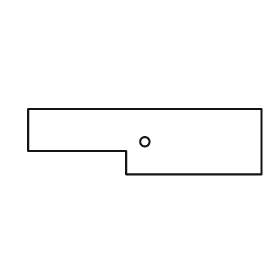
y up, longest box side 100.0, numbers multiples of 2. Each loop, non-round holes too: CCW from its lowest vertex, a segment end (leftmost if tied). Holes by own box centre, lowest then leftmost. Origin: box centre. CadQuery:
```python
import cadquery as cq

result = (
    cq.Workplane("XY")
    .moveTo(-8.0, -14.0)
    .lineTo(50.0, -14.0)
    .lineTo(50.0, 14.0)
    .lineTo(-50.0, 14.0)
    .lineTo(-50.0, -4.0)
    .lineTo(-8.0, -4.0)
    .close()
    .moveTo(0.0, 0.0)
    .circle(2.0)
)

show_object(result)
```